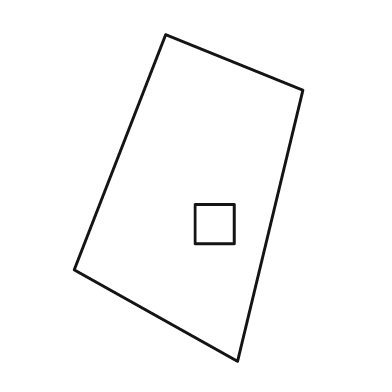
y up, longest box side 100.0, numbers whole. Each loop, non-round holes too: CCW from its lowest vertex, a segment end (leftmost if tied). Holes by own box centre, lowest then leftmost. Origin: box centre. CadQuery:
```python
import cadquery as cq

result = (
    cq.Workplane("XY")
    .moveTo(15.0, -50.0)
    .lineTo(35.0, 33.0)
    .lineTo(-7.0, 50.0)
    .lineTo(-35.0, -22.0)
    .close()
    .moveTo(2.0, -14.0)
    .lineTo(14.0, -14.0)
    .lineTo(14.0, -2.0)
    .lineTo(2.0, -2.0)
    .close()
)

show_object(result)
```